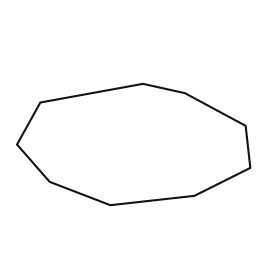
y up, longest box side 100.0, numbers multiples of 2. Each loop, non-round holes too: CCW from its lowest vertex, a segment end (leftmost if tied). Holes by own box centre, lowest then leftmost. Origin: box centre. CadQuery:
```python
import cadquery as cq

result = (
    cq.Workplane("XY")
    .moveTo(-10.0, -26.0)
    .lineTo(26.0, -22.0)
    .lineTo(50.0, -10.0)
    .lineTo(48.0, 8.0)
    .lineTo(22.0, 22.0)
    .lineTo(4.0, 26.0)
    .lineTo(-40.0, 18.0)
    .lineTo(-50.0, 0.0)
    .lineTo(-36.0, -16.0)
    .close()
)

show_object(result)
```